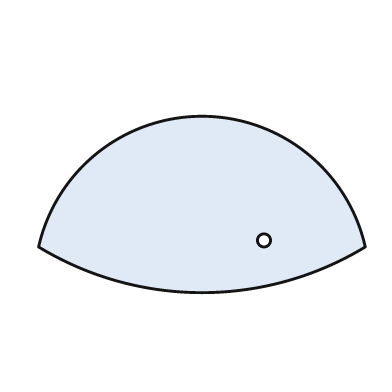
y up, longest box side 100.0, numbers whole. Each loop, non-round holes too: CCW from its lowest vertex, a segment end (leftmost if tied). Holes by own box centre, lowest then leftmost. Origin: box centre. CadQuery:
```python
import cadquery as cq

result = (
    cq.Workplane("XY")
    .moveTo(-50.0, -13.0)
    .threePointArc((0.0, -27.0), (50.0, -13.0))
    .threePointArc((0.0, 27.0), (-50.0, -13.0))
    .close()
    .moveTo(19.0, -11.0)
    .circle(2.0)
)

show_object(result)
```